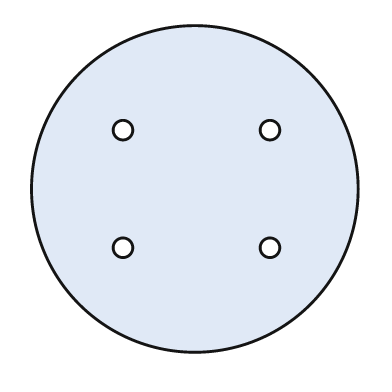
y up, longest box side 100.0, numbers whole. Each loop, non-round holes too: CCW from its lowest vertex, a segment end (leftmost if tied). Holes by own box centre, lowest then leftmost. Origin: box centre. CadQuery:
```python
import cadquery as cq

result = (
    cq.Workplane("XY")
    .moveTo(0.0, 0.0)
    .circle(50.0)
    .moveTo(-22.0, -18.0)
    .circle(3.0)
    .moveTo(23.0, -18.0)
    .circle(3.0)
    .moveTo(-22.0, 18.0)
    .circle(3.0)
    .moveTo(23.0, 18.0)
    .circle(3.0)
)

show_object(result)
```